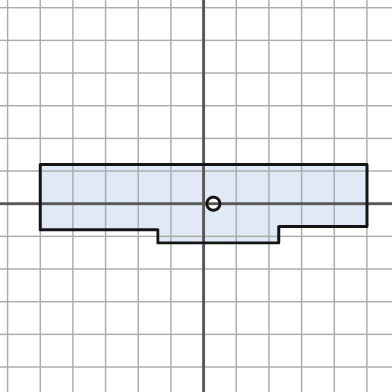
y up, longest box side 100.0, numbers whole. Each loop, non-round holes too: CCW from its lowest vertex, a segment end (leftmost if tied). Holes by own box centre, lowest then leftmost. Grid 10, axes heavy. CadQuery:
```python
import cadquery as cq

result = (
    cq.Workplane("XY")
    .moveTo(-14.0, -12.0)
    .lineTo(23.0, -12.0)
    .lineTo(23.0, -7.0)
    .lineTo(50.0, -7.0)
    .lineTo(50.0, 12.0)
    .lineTo(-50.0, 12.0)
    .lineTo(-50.0, -8.0)
    .lineTo(-14.0, -8.0)
    .close()
    .moveTo(3.0, 0.0)
    .circle(2.0)
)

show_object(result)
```